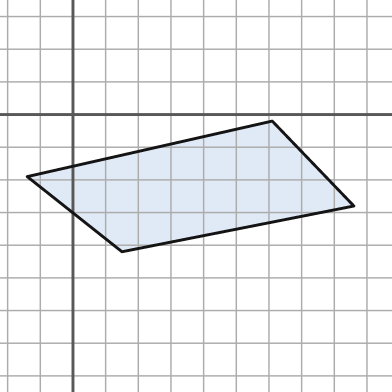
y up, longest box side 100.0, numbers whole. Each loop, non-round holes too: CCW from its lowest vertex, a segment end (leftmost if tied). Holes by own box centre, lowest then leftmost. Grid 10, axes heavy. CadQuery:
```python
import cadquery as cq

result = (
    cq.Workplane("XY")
    .moveTo(15.0, -42.0)
    .lineTo(86.0, -28.0)
    .lineTo(61.0, -2.0)
    .lineTo(-14.0, -19.0)
    .close()
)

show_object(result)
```